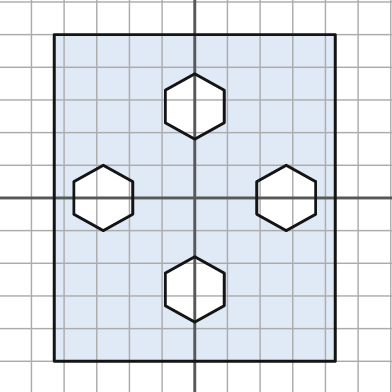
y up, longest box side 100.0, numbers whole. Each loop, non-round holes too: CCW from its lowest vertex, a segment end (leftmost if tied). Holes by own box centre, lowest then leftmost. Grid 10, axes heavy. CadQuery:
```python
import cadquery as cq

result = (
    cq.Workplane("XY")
    .moveTo(-43.0, -50.0)
    .lineTo(43.0, -50.0)
    .lineTo(43.0, 50.0)
    .lineTo(-43.0, 50.0)
    .close()
    .moveTo(0.0, -38.0)
    .lineTo(9.0, -33.0)
    .lineTo(9.0, -23.0)
    .lineTo(0.0, -18.0)
    .lineTo(-9.0, -23.0)
    .lineTo(-9.0, -33.0)
    .close()
    .moveTo(-28.0, -10.0)
    .lineTo(-19.0, -5.0)
    .lineTo(-19.0, 5.0)
    .lineTo(-28.0, 10.0)
    .lineTo(-37.0, 5.0)
    .lineTo(-37.0, -5.0)
    .close()
    .moveTo(28.0, -10.0)
    .lineTo(37.0, -5.0)
    .lineTo(37.0, 5.0)
    .lineTo(28.0, 10.0)
    .lineTo(19.0, 5.0)
    .lineTo(19.0, -5.0)
    .close()
    .moveTo(0.0, 18.0)
    .lineTo(9.0, 23.0)
    .lineTo(9.0, 33.0)
    .lineTo(0.0, 38.0)
    .lineTo(-9.0, 33.0)
    .lineTo(-9.0, 23.0)
    .close()
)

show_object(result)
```